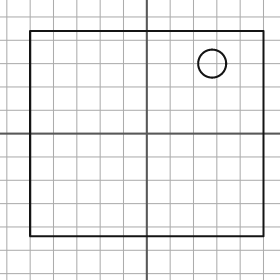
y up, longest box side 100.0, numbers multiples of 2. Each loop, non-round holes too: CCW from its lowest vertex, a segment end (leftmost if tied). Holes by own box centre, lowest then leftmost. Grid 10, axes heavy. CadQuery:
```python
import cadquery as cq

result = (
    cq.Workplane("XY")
    .moveTo(-50.0, -44.0)
    .lineTo(50.0, -44.0)
    .lineTo(50.0, 44.0)
    .lineTo(-50.0, 44.0)
    .close()
    .moveTo(28.0, 30.0)
    .circle(6.0)
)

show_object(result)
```